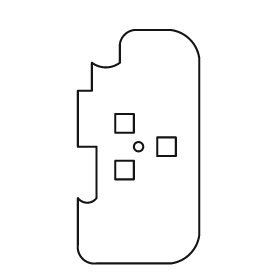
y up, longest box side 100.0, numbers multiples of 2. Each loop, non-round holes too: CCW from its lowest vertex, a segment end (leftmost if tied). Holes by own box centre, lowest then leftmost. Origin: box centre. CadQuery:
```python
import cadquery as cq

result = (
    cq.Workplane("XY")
    .moveTo(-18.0, -50.0)
    .lineTo(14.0, -50.0)
    .threePointArc((22.0, -46.0), (26.0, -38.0))
    .lineTo(26.0, 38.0)
    .threePointArc((22.0, 46.0), (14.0, 50.0))
    .lineTo(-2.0, 50.0)
    .threePointArc((-6.0, 48.0), (-8.0, 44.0))
    .lineTo(-8.0, 36.0)
    .threePointArc((-14.0, 34.0), (-20.0, 36.0))
    .lineTo(-20.0, 24.0)
    .lineTo(-26.0, 24.0)
    .lineTo(-26.0, 0.0)
    .lineTo(-18.0, 0.0)
    .lineTo(-18.0, -22.0)
    .threePointArc((-22.0, -24.0), (-26.0, -22.0))
    .lineTo(-26.0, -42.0)
    .threePointArc((-24.0, -48.0), (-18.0, -50.0))
    .close()
    .moveTo(-10.0, -14.0)
    .lineTo(-2.0, -14.0)
    .lineTo(-2.0, -6.0)
    .lineTo(-10.0, -6.0)
    .close()
    .moveTo(0.0, 0.0)
    .circle(2.0)
    .moveTo(8.0, -4.0)
    .lineTo(16.0, -4.0)
    .lineTo(16.0, 4.0)
    .lineTo(8.0, 4.0)
    .close()
    .moveTo(-10.0, 6.0)
    .lineTo(-2.0, 6.0)
    .lineTo(-2.0, 14.0)
    .lineTo(-10.0, 14.0)
    .close()
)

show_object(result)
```